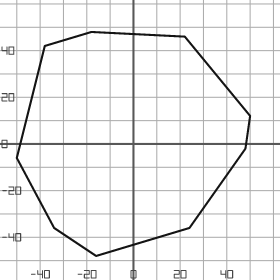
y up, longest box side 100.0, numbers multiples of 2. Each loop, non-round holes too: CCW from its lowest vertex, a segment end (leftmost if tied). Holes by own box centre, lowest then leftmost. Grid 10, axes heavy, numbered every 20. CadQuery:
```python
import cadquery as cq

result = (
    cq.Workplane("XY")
    .moveTo(-16.0, -48.0)
    .lineTo(24.0, -36.0)
    .lineTo(48.0, -2.0)
    .lineTo(50.0, 12.0)
    .lineTo(22.0, 46.0)
    .lineTo(-18.0, 48.0)
    .lineTo(-38.0, 42.0)
    .lineTo(-50.0, -6.0)
    .lineTo(-34.0, -36.0)
    .close()
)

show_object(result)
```